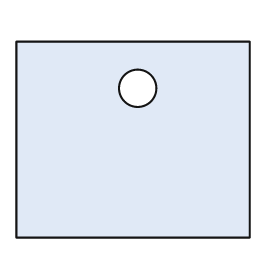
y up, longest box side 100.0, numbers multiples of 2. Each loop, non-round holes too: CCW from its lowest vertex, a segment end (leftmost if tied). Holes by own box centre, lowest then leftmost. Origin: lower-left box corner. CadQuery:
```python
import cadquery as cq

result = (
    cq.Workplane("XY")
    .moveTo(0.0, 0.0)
    .lineTo(100.0, 0.0)
    .lineTo(100.0, 84.0)
    .lineTo(0.0, 84.0)
    .close()
    .moveTo(52.0, 64.0)
    .circle(8.0)
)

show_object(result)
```